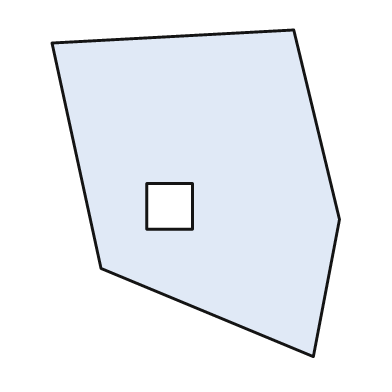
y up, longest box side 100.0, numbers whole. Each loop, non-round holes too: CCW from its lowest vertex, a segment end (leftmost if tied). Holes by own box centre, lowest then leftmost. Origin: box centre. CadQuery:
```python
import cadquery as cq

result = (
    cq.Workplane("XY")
    .moveTo(36.0, -50.0)
    .lineTo(44.0, -8.0)
    .lineTo(30.0, 50.0)
    .lineTo(-44.0, 46.0)
    .lineTo(-29.0, -23.0)
    .close()
    .moveTo(-15.0, -11.0)
    .lineTo(-1.0, -11.0)
    .lineTo(-1.0, 3.0)
    .lineTo(-15.0, 3.0)
    .close()
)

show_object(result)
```